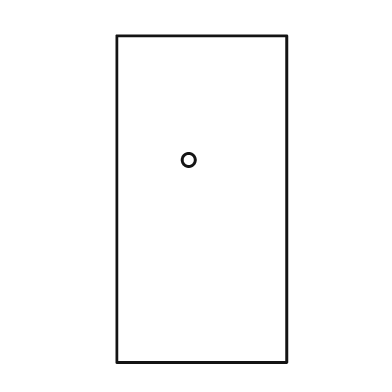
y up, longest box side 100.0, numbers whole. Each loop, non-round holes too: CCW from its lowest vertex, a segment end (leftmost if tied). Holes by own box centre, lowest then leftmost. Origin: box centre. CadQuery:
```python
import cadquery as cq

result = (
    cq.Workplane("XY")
    .moveTo(-26.0, -50.0)
    .lineTo(26.0, -50.0)
    .lineTo(26.0, 50.0)
    .lineTo(-26.0, 50.0)
    .close()
    .moveTo(-4.0, 12.0)
    .circle(2.0)
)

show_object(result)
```